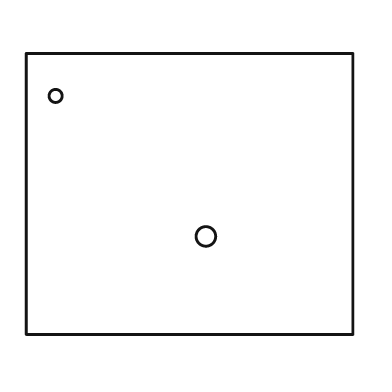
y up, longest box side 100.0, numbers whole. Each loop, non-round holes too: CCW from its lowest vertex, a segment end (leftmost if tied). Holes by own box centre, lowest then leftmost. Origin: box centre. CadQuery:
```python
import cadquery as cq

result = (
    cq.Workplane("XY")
    .moveTo(-50.0, -43.0)
    .lineTo(50.0, -43.0)
    .lineTo(50.0, 43.0)
    .lineTo(-50.0, 43.0)
    .close()
    .moveTo(5.0, -13.0)
    .circle(3.0)
    .moveTo(-41.0, 30.0)
    .circle(2.0)
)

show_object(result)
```